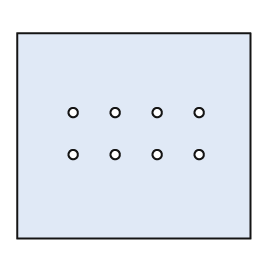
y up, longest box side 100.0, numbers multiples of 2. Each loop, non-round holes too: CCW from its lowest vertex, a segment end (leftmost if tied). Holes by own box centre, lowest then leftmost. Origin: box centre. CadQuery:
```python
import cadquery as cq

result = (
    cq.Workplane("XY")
    .moveTo(-50.0, -44.0)
    .lineTo(50.0, -44.0)
    .lineTo(50.0, 44.0)
    .lineTo(-50.0, 44.0)
    .close()
    .moveTo(-26.0, -8.0)
    .circle(2.0)
    .moveTo(-8.0, -8.0)
    .circle(2.0)
    .moveTo(10.0, -8.0)
    .circle(2.0)
    .moveTo(28.0, -8.0)
    .circle(2.0)
    .moveTo(-26.0, 10.0)
    .circle(2.0)
    .moveTo(-8.0, 10.0)
    .circle(2.0)
    .moveTo(10.0, 10.0)
    .circle(2.0)
    .moveTo(28.0, 10.0)
    .circle(2.0)
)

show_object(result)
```